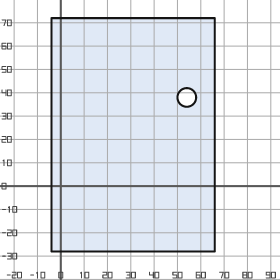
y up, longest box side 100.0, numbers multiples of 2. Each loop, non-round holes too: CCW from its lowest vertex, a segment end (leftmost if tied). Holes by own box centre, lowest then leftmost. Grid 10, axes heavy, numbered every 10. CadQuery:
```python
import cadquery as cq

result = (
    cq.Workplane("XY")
    .moveTo(-4.0, -28.0)
    .lineTo(66.0, -28.0)
    .lineTo(66.0, 72.0)
    .lineTo(-4.0, 72.0)
    .close()
    .moveTo(54.0, 38.0)
    .circle(4.0)
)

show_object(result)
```